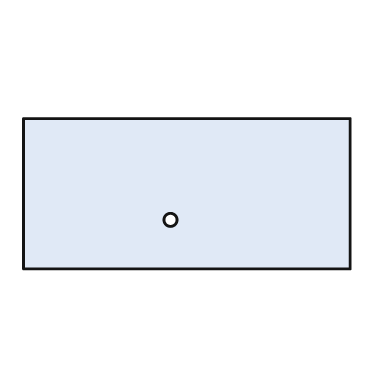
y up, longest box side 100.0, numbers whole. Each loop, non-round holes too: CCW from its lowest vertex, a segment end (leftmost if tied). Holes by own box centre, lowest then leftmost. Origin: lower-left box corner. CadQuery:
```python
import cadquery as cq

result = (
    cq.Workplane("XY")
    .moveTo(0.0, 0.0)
    .lineTo(100.0, 0.0)
    .lineTo(100.0, 46.0)
    .lineTo(0.0, 46.0)
    .close()
    .moveTo(45.0, 15.0)
    .circle(2.0)
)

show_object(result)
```